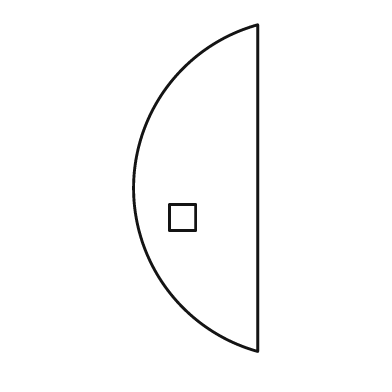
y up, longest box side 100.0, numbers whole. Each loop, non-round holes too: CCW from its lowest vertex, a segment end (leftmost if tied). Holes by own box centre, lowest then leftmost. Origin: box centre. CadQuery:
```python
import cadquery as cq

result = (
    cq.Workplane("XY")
    .moveTo(19.0, -50.0)
    .lineTo(19.0, 50.0)
    .threePointArc((-19.0, 0.0), (19.0, -50.0))
    .close()
    .moveTo(-8.0, -13.0)
    .lineTo(0.0, -13.0)
    .lineTo(0.0, -5.0)
    .lineTo(-8.0, -5.0)
    .close()
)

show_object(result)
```